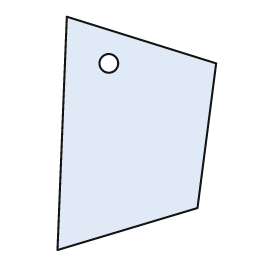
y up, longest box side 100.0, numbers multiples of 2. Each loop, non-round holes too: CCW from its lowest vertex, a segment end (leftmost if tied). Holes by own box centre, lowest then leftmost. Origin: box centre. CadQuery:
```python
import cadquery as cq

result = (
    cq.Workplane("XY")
    .moveTo(-34.0, -50.0)
    .lineTo(26.0, -32.0)
    .lineTo(34.0, 30.0)
    .lineTo(-30.0, 50.0)
    .close()
    .moveTo(-12.0, 30.0)
    .circle(4.0)
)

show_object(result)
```